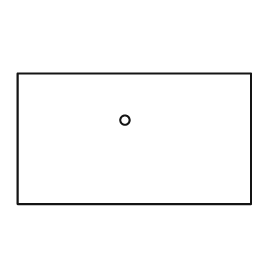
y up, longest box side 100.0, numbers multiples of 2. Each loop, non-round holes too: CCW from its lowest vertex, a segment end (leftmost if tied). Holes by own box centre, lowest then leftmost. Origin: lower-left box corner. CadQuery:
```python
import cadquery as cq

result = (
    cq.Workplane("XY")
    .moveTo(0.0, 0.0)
    .lineTo(100.0, 0.0)
    .lineTo(100.0, 56.0)
    .lineTo(0.0, 56.0)
    .close()
    .moveTo(46.0, 36.0)
    .circle(2.0)
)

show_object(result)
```